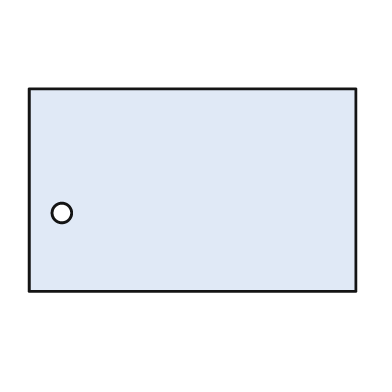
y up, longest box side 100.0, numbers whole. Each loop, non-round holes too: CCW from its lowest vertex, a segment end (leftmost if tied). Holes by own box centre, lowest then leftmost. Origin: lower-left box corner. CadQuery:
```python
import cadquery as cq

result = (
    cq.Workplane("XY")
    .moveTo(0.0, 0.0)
    .lineTo(100.0, 0.0)
    .lineTo(100.0, 62.0)
    .lineTo(0.0, 62.0)
    .close()
    .moveTo(10.0, 24.0)
    .circle(3.0)
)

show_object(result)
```